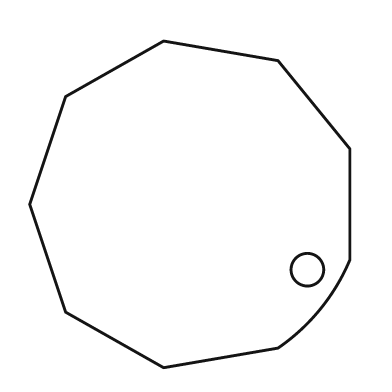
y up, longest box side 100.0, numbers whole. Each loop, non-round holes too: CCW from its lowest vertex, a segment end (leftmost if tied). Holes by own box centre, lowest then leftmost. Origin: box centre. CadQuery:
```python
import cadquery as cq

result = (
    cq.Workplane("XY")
    .moveTo(-8.0, -50.0)
    .lineTo(27.0, -44.0)
    .threePointArc((40.0, -32.0), (49.0, -17.0))
    .lineTo(49.0, 17.0)
    .lineTo(27.0, 44.0)
    .lineTo(-8.0, 50.0)
    .lineTo(-38.0, 33.0)
    .lineTo(-49.0, 0.0)
    .lineTo(-38.0, -33.0)
    .close()
    .moveTo(36.0, -20.0)
    .circle(5.0)
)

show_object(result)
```